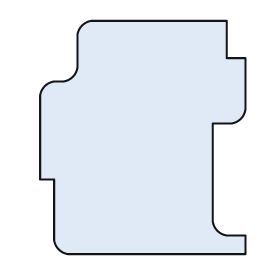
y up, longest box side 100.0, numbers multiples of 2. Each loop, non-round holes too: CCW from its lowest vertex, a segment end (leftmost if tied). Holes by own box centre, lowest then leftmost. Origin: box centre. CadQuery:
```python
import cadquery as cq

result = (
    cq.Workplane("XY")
    .moveTo(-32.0, -50.0)
    .lineTo(44.0, -50.0)
    .lineTo(44.0, -42.0)
    .lineTo(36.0, -42.0)
    .threePointArc((32.0, -40.0), (30.0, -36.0))
    .lineTo(30.0, 6.0)
    .lineTo(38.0, 6.0)
    .threePointArc((42.0, 8.0), (44.0, 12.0))
    .lineTo(44.0, 34.0)
    .lineTo(36.0, 34.0)
    .lineTo(36.0, 50.0)
    .lineTo(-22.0, 50.0)
    .threePointArc((-26.0, 48.0), (-28.0, 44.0))
    .lineTo(-28.0, 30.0)
    .threePointArc((-30.0, 26.0), (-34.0, 24.0))
    .lineTo(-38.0, 24.0)
    .threePointArc((-42.0, 22.0), (-44.0, 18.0))
    .lineTo(-44.0, -18.0)
    .lineTo(-38.0, -18.0)
    .lineTo(-38.0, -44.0)
    .threePointArc((-36.0, -48.0), (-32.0, -50.0))
    .close()
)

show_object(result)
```